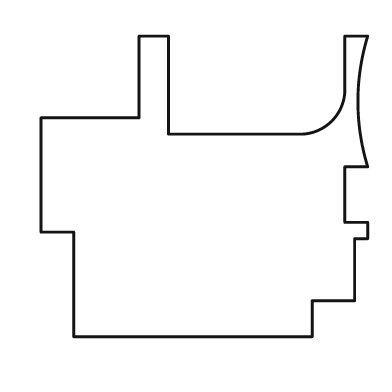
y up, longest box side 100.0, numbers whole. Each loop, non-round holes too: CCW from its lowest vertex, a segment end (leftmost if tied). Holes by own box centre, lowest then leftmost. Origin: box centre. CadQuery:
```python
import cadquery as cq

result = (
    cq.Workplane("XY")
    .moveTo(-40.0, -46.0)
    .lineTo(33.0, -46.0)
    .lineTo(33.0, -35.0)
    .lineTo(46.0, -35.0)
    .lineTo(46.0, -16.0)
    .lineTo(50.0, -16.0)
    .lineTo(50.0, -11.0)
    .lineTo(43.0, -11.0)
    .lineTo(43.0, 6.0)
    .lineTo(50.0, 6.0)
    .threePointArc((47.0, 26.0), (50.0, 46.0))
    .lineTo(43.0, 46.0)
    .lineTo(43.0, 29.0)
    .threePointArc((39.0, 20.0), (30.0, 16.0))
    .lineTo(-11.0, 16.0)
    .lineTo(-11.0, 46.0)
    .lineTo(-20.0, 46.0)
    .lineTo(-20.0, 21.0)
    .lineTo(-50.0, 21.0)
    .lineTo(-50.0, -14.0)
    .lineTo(-40.0, -14.0)
    .close()
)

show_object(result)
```